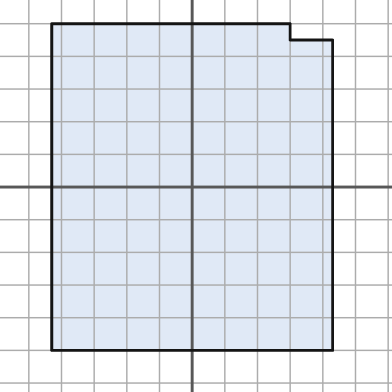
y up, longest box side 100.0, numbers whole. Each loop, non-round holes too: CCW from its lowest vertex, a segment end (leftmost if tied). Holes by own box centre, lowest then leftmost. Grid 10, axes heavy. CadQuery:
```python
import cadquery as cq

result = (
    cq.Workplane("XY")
    .moveTo(-43.0, -50.0)
    .lineTo(43.0, -50.0)
    .lineTo(43.0, 45.0)
    .lineTo(30.0, 45.0)
    .lineTo(30.0, 50.0)
    .lineTo(-43.0, 50.0)
    .close()
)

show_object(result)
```